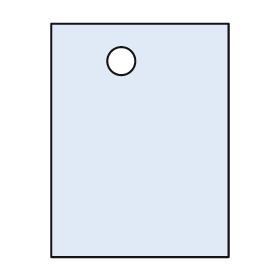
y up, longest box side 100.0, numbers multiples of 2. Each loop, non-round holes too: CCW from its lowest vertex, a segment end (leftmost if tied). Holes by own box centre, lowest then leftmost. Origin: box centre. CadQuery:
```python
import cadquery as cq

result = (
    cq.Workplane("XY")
    .moveTo(-38.0, -50.0)
    .lineTo(38.0, -50.0)
    .lineTo(38.0, 50.0)
    .lineTo(-38.0, 50.0)
    .close()
    .moveTo(-8.0, 34.0)
    .circle(6.0)
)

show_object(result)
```